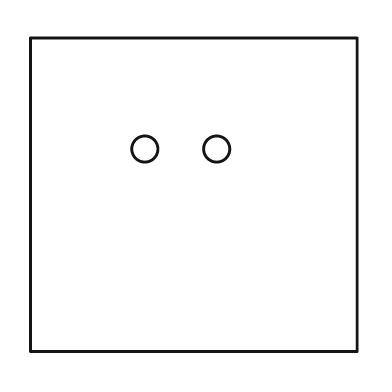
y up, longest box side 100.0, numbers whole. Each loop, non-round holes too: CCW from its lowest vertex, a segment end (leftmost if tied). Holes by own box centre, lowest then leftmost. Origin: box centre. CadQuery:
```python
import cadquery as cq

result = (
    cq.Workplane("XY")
    .moveTo(-50.0, -48.0)
    .lineTo(50.0, -48.0)
    .lineTo(50.0, 48.0)
    .lineTo(-50.0, 48.0)
    .close()
    .moveTo(-15.0, 14.0)
    .circle(4.0)
    .moveTo(7.0, 14.0)
    .circle(4.0)
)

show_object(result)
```